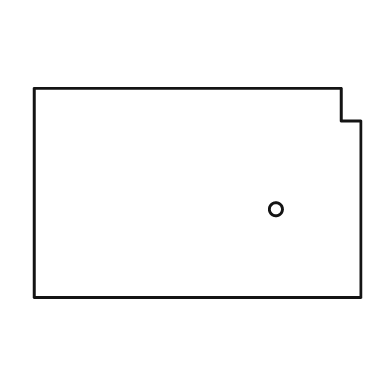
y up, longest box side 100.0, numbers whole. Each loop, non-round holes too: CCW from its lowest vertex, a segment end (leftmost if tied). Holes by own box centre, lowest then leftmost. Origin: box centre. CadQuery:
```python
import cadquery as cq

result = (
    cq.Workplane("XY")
    .moveTo(-50.0, -32.0)
    .lineTo(50.0, -32.0)
    .lineTo(50.0, 22.0)
    .lineTo(44.0, 22.0)
    .lineTo(44.0, 32.0)
    .lineTo(-50.0, 32.0)
    .close()
    .moveTo(24.0, -5.0)
    .circle(2.0)
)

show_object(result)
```